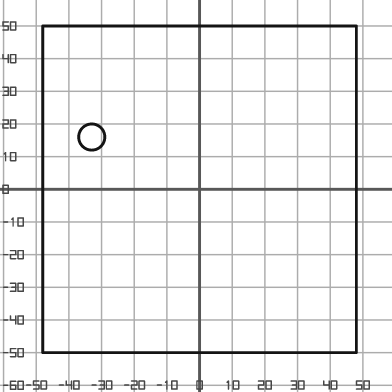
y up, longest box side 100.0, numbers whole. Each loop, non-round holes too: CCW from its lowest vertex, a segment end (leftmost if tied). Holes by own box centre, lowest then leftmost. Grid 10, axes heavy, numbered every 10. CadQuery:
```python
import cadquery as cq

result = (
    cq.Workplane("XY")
    .moveTo(-48.0, -50.0)
    .lineTo(48.0, -50.0)
    .lineTo(48.0, 50.0)
    .lineTo(-48.0, 50.0)
    .close()
    .moveTo(-33.0, 16.0)
    .circle(4.0)
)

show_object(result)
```